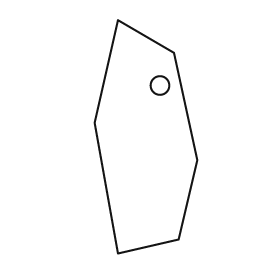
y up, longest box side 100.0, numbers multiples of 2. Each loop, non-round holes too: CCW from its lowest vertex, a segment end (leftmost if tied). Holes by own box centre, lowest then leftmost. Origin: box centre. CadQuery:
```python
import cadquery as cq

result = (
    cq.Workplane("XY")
    .moveTo(-12.0, -50.0)
    .lineTo(14.0, -44.0)
    .lineTo(22.0, -10.0)
    .lineTo(12.0, 36.0)
    .lineTo(-12.0, 50.0)
    .lineTo(-22.0, 6.0)
    .close()
    .moveTo(6.0, 22.0)
    .circle(4.0)
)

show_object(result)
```